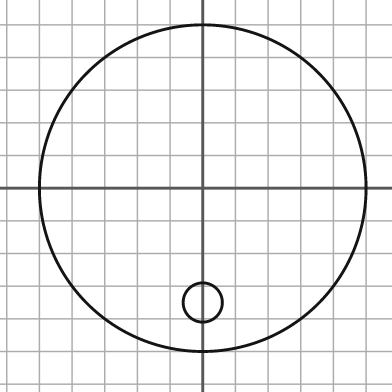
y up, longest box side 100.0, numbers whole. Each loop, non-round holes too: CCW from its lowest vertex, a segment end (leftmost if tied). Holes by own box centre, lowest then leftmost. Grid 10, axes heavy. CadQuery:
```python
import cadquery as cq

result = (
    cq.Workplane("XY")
    .moveTo(0.0, 0.0)
    .circle(50.0)
    .moveTo(0.0, -35.0)
    .circle(6.0)
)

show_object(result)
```